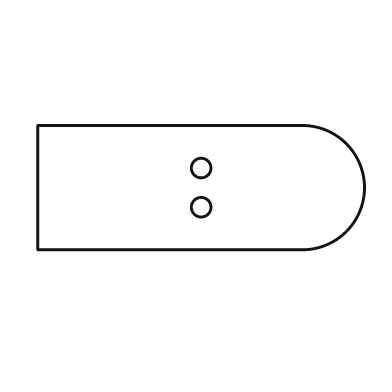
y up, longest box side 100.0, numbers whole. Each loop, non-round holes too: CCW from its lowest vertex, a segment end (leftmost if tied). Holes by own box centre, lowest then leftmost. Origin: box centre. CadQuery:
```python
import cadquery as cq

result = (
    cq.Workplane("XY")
    .moveTo(-50.0, -19.0)
    .lineTo(32.0, -19.0)
    .threePointArc((50.0, 0.0), (32.0, 19.0))
    .lineTo(-50.0, 19.0)
    .close()
    .moveTo(0.0, -6.0)
    .circle(3.0)
    .moveTo(0.0, 6.0)
    .circle(3.0)
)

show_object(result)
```